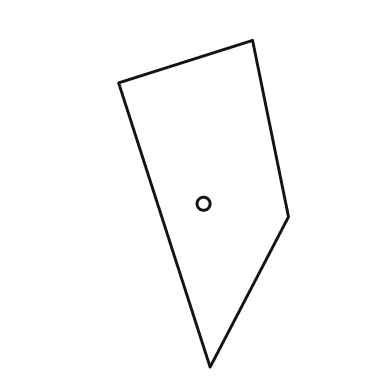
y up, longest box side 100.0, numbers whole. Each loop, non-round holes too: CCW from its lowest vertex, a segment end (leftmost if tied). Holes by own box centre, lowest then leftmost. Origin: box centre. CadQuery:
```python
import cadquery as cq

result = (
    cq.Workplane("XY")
    .moveTo(2.0, -50.0)
    .lineTo(26.0, -4.0)
    .lineTo(15.0, 50.0)
    .lineTo(-26.0, 37.0)
    .close()
    .moveTo(0.0, 0.0)
    .circle(2.0)
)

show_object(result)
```